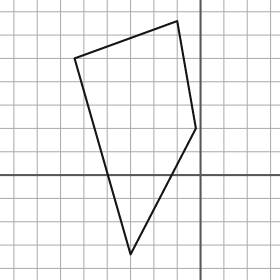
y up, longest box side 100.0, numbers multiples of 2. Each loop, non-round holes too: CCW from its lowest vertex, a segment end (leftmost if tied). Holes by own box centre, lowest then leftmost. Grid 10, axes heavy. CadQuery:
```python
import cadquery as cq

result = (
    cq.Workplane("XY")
    .moveTo(-30.0, -34.0)
    .lineTo(-2.0, 20.0)
    .lineTo(-10.0, 66.0)
    .lineTo(-54.0, 50.0)
    .close()
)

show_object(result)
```